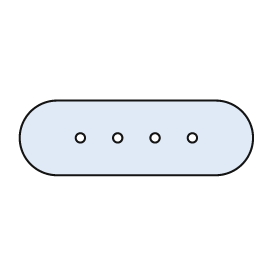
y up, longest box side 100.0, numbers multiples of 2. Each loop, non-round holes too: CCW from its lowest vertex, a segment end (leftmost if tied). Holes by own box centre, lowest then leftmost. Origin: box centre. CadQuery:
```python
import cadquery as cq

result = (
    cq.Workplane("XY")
    .moveTo(-34.0, -16.0)
    .lineTo(34.0, -16.0)
    .threePointArc((50.0, 0.0), (34.0, 16.0))
    .lineTo(-34.0, 16.0)
    .threePointArc((-50.0, 0.0), (-34.0, -16.0))
    .close()
    .moveTo(-24.0, 0.0)
    .circle(2.0)
    .moveTo(-8.0, 0.0)
    .circle(2.0)
    .moveTo(8.0, 0.0)
    .circle(2.0)
    .moveTo(24.0, 0.0)
    .circle(2.0)
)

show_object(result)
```